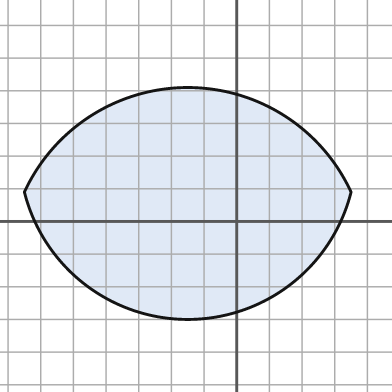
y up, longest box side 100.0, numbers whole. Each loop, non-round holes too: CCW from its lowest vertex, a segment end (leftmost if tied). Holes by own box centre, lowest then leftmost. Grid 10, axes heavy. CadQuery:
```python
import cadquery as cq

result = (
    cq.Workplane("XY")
    .moveTo(-65.0, 9.0)
    .threePointArc((-15.0, -30.0), (35.0, 9.0))
    .threePointArc((-15.0, 41.0), (-65.0, 9.0))
    .close()
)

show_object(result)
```